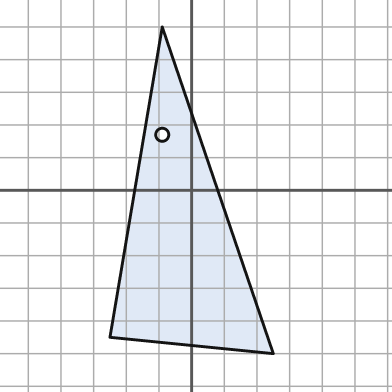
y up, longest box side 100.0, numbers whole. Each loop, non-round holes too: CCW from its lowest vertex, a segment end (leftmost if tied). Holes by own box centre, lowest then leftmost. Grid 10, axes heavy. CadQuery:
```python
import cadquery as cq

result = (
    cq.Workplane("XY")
    .moveTo(25.0, -50.0)
    .lineTo(-9.0, 50.0)
    .lineTo(-25.0, -45.0)
    .close()
    .moveTo(-9.0, 17.0)
    .circle(2.0)
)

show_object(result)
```